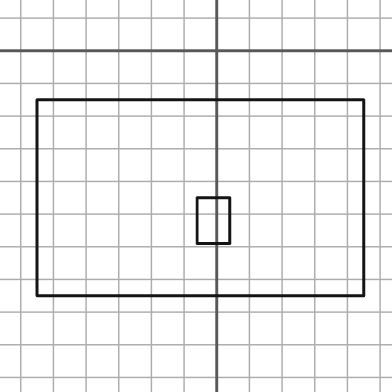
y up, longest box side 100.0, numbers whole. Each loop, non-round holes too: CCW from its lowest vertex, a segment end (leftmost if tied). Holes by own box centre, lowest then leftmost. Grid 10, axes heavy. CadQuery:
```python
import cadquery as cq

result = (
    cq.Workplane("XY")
    .moveTo(-55.0, -75.0)
    .lineTo(45.0, -75.0)
    .lineTo(45.0, -15.0)
    .lineTo(-55.0, -15.0)
    .close()
    .moveTo(-6.0, -59.0)
    .lineTo(4.0, -59.0)
    .lineTo(4.0, -45.0)
    .lineTo(-6.0, -45.0)
    .close()
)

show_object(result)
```